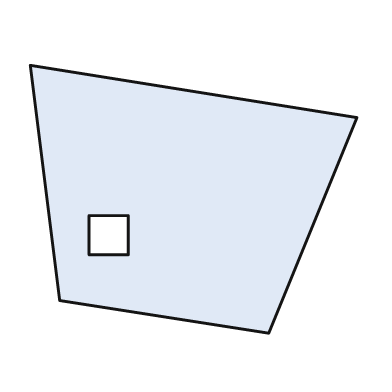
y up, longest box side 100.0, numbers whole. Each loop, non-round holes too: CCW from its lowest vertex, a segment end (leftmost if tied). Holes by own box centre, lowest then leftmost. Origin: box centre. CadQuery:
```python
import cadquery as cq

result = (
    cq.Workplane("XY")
    .moveTo(23.0, -41.0)
    .lineTo(50.0, 25.0)
    .lineTo(-50.0, 41.0)
    .lineTo(-41.0, -31.0)
    .close()
    .moveTo(-32.0, -17.0)
    .lineTo(-20.0, -17.0)
    .lineTo(-20.0, -5.0)
    .lineTo(-32.0, -5.0)
    .close()
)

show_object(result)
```